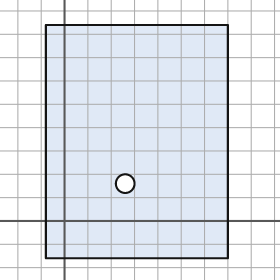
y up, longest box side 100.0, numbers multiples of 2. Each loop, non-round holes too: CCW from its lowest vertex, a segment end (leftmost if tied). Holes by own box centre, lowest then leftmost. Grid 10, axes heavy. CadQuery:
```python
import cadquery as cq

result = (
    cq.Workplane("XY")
    .moveTo(-8.0, -16.0)
    .lineTo(70.0, -16.0)
    .lineTo(70.0, 84.0)
    .lineTo(-8.0, 84.0)
    .close()
    .moveTo(26.0, 16.0)
    .circle(4.0)
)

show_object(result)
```